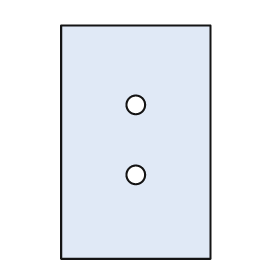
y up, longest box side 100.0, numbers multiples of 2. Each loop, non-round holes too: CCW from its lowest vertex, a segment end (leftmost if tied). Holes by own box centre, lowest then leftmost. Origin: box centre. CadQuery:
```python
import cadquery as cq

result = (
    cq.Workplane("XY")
    .moveTo(-32.0, -50.0)
    .lineTo(32.0, -50.0)
    .lineTo(32.0, 50.0)
    .lineTo(-32.0, 50.0)
    .close()
    .moveTo(0.0, -14.0)
    .circle(4.0)
    .moveTo(0.0, 16.0)
    .circle(4.0)
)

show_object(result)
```